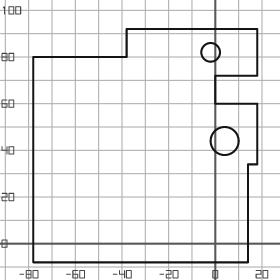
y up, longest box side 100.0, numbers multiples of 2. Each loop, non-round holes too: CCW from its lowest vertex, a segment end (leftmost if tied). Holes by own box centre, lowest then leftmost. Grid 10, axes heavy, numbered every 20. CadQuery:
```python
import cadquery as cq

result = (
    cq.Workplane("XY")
    .moveTo(-78.0, -8.0)
    .lineTo(14.0, -8.0)
    .lineTo(14.0, 34.0)
    .lineTo(18.0, 34.0)
    .lineTo(18.0, 60.0)
    .lineTo(0.0, 60.0)
    .lineTo(0.0, 72.0)
    .lineTo(18.0, 72.0)
    .lineTo(18.0, 92.0)
    .lineTo(-38.0, 92.0)
    .lineTo(-38.0, 80.0)
    .lineTo(-78.0, 80.0)
    .close()
    .moveTo(4.0, 44.0)
    .circle(6.0)
    .moveTo(-2.0, 82.0)
    .circle(4.0)
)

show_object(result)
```